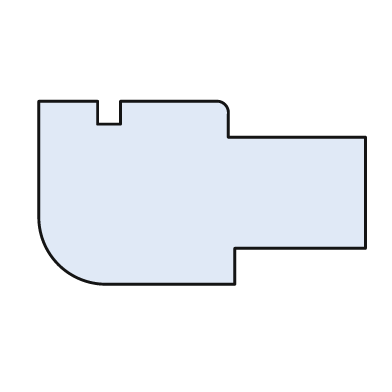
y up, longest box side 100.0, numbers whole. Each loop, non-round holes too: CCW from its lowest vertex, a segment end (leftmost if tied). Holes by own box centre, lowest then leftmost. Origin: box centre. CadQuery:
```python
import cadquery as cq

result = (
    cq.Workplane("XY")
    .moveTo(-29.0, -28.0)
    .lineTo(10.0, -28.0)
    .lineTo(10.0, -17.0)
    .lineTo(50.0, -17.0)
    .lineTo(50.0, 17.0)
    .lineTo(8.0, 17.0)
    .lineTo(8.0, 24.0)
    .threePointArc((7.0, 27.0), (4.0, 28.0))
    .lineTo(-25.0, 28.0)
    .lineTo(-25.0, 21.0)
    .lineTo(-32.0, 21.0)
    .lineTo(-32.0, 28.0)
    .lineTo(-50.0, 28.0)
    .lineTo(-50.0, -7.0)
    .threePointArc((-44.0, -22.0), (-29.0, -28.0))
    .close()
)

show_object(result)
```